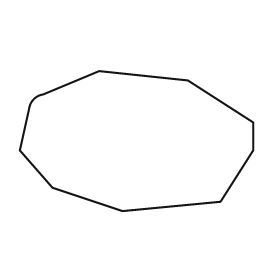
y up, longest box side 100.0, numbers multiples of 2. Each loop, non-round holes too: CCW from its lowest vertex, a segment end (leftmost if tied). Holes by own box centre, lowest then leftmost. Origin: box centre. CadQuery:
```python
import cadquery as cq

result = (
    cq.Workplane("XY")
    .moveTo(-6.0, -30.0)
    .lineTo(36.0, -26.0)
    .lineTo(50.0, -4.0)
    .lineTo(50.0, 8.0)
    .lineTo(22.0, 26.0)
    .lineTo(-16.0, 30.0)
    .lineTo(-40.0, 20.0)
    .threePointArc((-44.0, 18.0), (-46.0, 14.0))
    .lineTo(-50.0, -4.0)
    .lineTo(-36.0, -20.0)
    .close()
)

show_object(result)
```